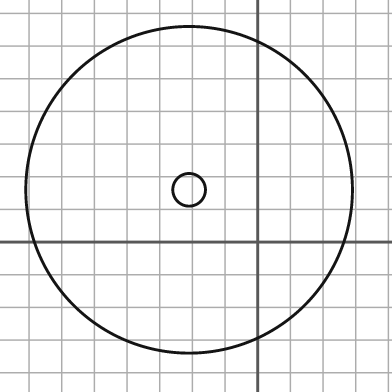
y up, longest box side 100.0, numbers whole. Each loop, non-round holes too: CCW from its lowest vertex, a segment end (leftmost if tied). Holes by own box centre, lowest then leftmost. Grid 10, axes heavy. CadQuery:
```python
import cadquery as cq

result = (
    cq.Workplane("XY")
    .moveTo(-21.0, 16.0)
    .circle(50.0)
    .moveTo(-21.0, 16.0)
    .circle(5.0)
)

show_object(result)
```